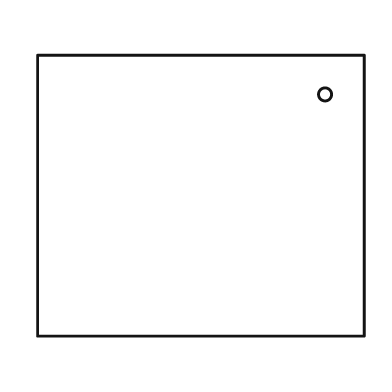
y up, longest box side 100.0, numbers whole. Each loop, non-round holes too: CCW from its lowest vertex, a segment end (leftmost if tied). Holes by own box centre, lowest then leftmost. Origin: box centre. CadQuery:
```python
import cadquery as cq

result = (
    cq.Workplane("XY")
    .moveTo(-50.0, -43.0)
    .lineTo(50.0, -43.0)
    .lineTo(50.0, 43.0)
    .lineTo(-50.0, 43.0)
    .close()
    .moveTo(38.0, 31.0)
    .circle(2.0)
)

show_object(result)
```